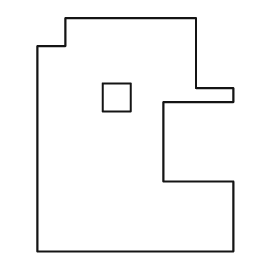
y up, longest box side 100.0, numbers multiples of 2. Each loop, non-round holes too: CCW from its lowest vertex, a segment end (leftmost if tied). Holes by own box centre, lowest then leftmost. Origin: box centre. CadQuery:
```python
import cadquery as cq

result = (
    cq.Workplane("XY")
    .moveTo(-42.0, -50.0)
    .lineTo(42.0, -50.0)
    .lineTo(42.0, -20.0)
    .lineTo(12.0, -20.0)
    .lineTo(12.0, 14.0)
    .lineTo(42.0, 14.0)
    .lineTo(42.0, 20.0)
    .lineTo(26.0, 20.0)
    .lineTo(26.0, 50.0)
    .lineTo(-30.0, 50.0)
    .lineTo(-30.0, 38.0)
    .lineTo(-42.0, 38.0)
    .close()
    .moveTo(-14.0, 10.0)
    .lineTo(-2.0, 10.0)
    .lineTo(-2.0, 22.0)
    .lineTo(-14.0, 22.0)
    .close()
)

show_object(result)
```